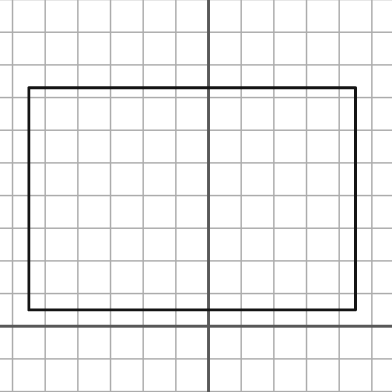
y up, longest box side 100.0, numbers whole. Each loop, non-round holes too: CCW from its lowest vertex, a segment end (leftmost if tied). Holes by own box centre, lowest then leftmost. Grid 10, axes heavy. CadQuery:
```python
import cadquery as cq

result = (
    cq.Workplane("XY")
    .moveTo(-55.0, 5.0)
    .lineTo(45.0, 5.0)
    .lineTo(45.0, 73.0)
    .lineTo(-55.0, 73.0)
    .close()
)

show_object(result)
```